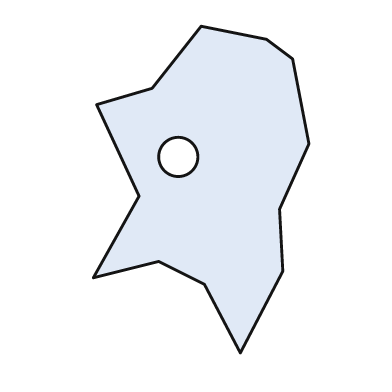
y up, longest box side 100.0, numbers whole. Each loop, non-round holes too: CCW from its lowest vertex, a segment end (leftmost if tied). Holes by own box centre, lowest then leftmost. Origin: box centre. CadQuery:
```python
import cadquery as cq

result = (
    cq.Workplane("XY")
    .moveTo(12.0, -50.0)
    .lineTo(25.0, -25.0)
    .lineTo(24.0, -6.0)
    .lineTo(33.0, 14.0)
    .lineTo(28.0, 40.0)
    .lineTo(20.0, 46.0)
    .lineTo(0.0, 50.0)
    .lineTo(-15.0, 31.0)
    .lineTo(-32.0, 26.0)
    .lineTo(-19.0, -2.0)
    .lineTo(-33.0, -27.0)
    .lineTo(-13.0, -22.0)
    .lineTo(1.0, -29.0)
    .close()
    .moveTo(-7.0, 10.0)
    .circle(6.0)
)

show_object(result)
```